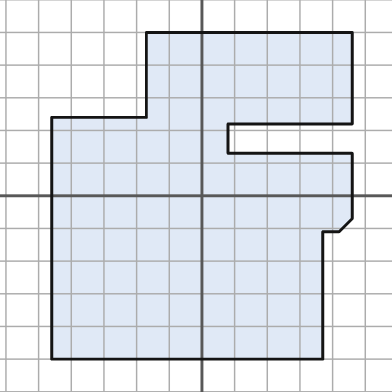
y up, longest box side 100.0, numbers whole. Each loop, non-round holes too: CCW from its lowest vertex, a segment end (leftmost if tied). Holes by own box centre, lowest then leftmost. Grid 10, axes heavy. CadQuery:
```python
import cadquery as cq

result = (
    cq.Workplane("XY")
    .moveTo(-46.0, -50.0)
    .lineTo(37.0, -50.0)
    .lineTo(37.0, -11.0)
    .lineTo(42.0, -11.0)
    .lineTo(46.0, -7.0)
    .lineTo(46.0, 13.0)
    .lineTo(8.0, 13.0)
    .lineTo(8.0, 22.0)
    .lineTo(46.0, 22.0)
    .lineTo(46.0, 50.0)
    .lineTo(-17.0, 50.0)
    .lineTo(-17.0, 24.0)
    .lineTo(-46.0, 24.0)
    .close()
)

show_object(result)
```